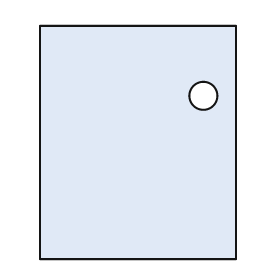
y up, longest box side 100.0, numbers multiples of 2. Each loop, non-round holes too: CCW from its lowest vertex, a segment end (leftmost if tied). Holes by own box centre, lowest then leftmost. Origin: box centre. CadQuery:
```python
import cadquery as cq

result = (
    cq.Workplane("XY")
    .moveTo(-42.0, -50.0)
    .lineTo(42.0, -50.0)
    .lineTo(42.0, 50.0)
    .lineTo(-42.0, 50.0)
    .close()
    .moveTo(28.0, 20.0)
    .circle(6.0)
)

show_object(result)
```